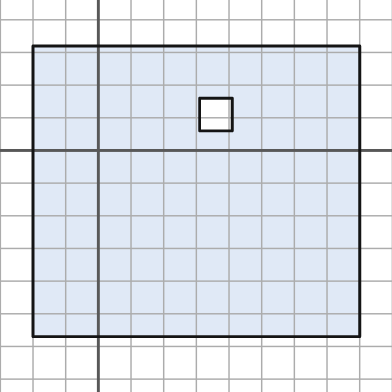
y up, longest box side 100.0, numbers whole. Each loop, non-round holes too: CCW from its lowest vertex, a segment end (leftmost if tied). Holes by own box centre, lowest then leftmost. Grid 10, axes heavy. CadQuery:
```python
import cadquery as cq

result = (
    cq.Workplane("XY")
    .moveTo(-20.0, -57.0)
    .lineTo(80.0, -57.0)
    .lineTo(80.0, 32.0)
    .lineTo(-20.0, 32.0)
    .close()
    .moveTo(31.0, 6.0)
    .lineTo(41.0, 6.0)
    .lineTo(41.0, 16.0)
    .lineTo(31.0, 16.0)
    .close()
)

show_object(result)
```